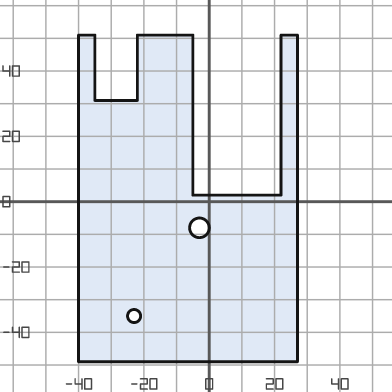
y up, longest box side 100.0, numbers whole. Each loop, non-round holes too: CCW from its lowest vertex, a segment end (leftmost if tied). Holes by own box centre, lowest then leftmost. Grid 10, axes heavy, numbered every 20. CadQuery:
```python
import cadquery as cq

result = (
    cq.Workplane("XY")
    .moveTo(-40.0, -49.0)
    .lineTo(27.0, -49.0)
    .lineTo(27.0, 51.0)
    .lineTo(22.0, 51.0)
    .lineTo(22.0, 2.0)
    .lineTo(-5.0, 2.0)
    .lineTo(-5.0, 51.0)
    .lineTo(-22.0, 51.0)
    .lineTo(-22.0, 31.0)
    .lineTo(-35.0, 31.0)
    .lineTo(-35.0, 51.0)
    .lineTo(-40.0, 51.0)
    .close()
    .moveTo(-23.0, -35.0)
    .circle(2.0)
    .moveTo(-3.0, -8.0)
    .circle(3.0)
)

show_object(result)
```